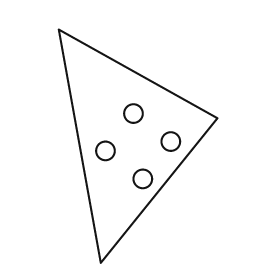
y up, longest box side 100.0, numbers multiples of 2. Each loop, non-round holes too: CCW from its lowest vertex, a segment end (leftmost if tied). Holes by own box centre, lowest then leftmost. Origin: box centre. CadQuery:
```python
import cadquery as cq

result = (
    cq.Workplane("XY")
    .moveTo(-16.0, -50.0)
    .lineTo(34.0, 12.0)
    .lineTo(-34.0, 50.0)
    .close()
    .moveTo(2.0, -14.0)
    .circle(4.0)
    .moveTo(-14.0, -2.0)
    .circle(4.0)
    .moveTo(14.0, 2.0)
    .circle(4.0)
    .moveTo(-2.0, 14.0)
    .circle(4.0)
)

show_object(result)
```